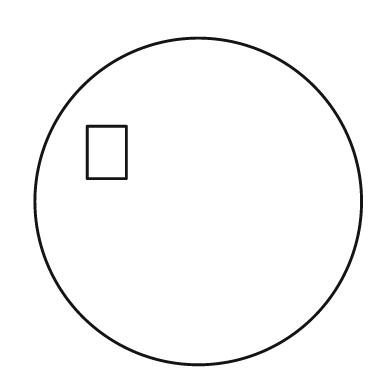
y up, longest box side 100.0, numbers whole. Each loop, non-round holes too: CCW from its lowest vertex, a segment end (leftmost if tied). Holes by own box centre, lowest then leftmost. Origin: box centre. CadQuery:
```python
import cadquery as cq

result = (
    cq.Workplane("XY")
    .moveTo(0.0, 0.0)
    .circle(50.0)
    .moveTo(-34.0, 7.0)
    .lineTo(-22.0, 7.0)
    .lineTo(-22.0, 23.0)
    .lineTo(-34.0, 23.0)
    .close()
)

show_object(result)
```